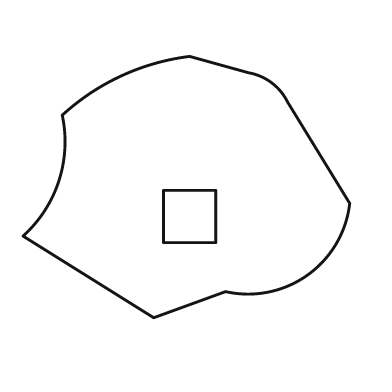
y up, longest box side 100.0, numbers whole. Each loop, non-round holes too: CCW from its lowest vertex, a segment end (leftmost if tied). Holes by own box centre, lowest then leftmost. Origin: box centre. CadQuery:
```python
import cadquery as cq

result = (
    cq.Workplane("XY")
    .moveTo(-10.0, -40.0)
    .lineTo(12.0, -32.0)
    .threePointArc((37.0, -27.0), (50.0, -5.0))
    .lineTo(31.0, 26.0)
    .threePointArc((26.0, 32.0), (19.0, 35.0))
    .lineTo(1.0, 40.0)
    .threePointArc((-20.0, 34.0), (-38.0, 22.0))
    .threePointArc((-39.0, 2.0), (-50.0, -15.0))
    .close()
    .moveTo(-7.0, -17.0)
    .lineTo(9.0, -17.0)
    .lineTo(9.0, -1.0)
    .lineTo(-7.0, -1.0)
    .close()
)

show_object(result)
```